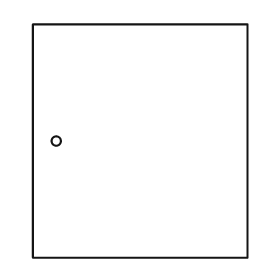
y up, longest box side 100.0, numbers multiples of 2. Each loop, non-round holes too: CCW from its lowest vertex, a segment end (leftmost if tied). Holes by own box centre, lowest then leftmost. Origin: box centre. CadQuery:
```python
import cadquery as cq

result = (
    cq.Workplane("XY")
    .moveTo(-46.0, -50.0)
    .lineTo(46.0, -50.0)
    .lineTo(46.0, 50.0)
    .lineTo(-46.0, 50.0)
    .close()
    .moveTo(-36.0, 0.0)
    .circle(2.0)
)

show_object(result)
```